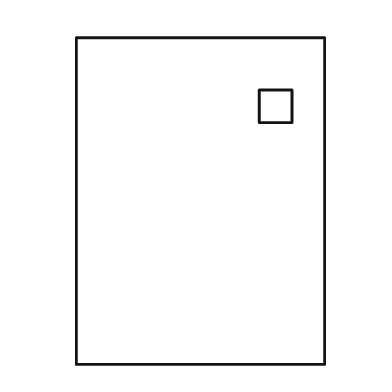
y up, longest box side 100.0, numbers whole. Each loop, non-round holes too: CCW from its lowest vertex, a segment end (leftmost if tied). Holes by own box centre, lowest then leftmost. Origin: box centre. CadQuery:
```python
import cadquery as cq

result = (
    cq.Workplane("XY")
    .moveTo(-38.0, -50.0)
    .lineTo(38.0, -50.0)
    .lineTo(38.0, 50.0)
    .lineTo(-38.0, 50.0)
    .close()
    .moveTo(18.0, 24.0)
    .lineTo(28.0, 24.0)
    .lineTo(28.0, 34.0)
    .lineTo(18.0, 34.0)
    .close()
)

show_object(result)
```